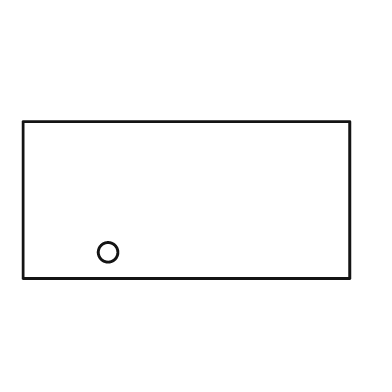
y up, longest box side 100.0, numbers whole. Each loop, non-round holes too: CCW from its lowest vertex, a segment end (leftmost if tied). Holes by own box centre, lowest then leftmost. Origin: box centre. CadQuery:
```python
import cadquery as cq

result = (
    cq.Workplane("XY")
    .moveTo(-50.0, -24.0)
    .lineTo(50.0, -24.0)
    .lineTo(50.0, 24.0)
    .lineTo(-50.0, 24.0)
    .close()
    .moveTo(-24.0, -16.0)
    .circle(3.0)
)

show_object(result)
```